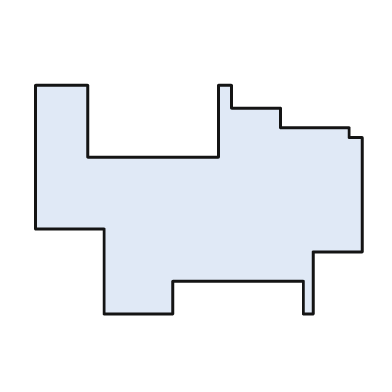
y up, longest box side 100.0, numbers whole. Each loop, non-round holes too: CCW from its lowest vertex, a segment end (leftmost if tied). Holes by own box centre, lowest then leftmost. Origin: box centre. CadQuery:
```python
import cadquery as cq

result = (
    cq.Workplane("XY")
    .moveTo(-29.0, -35.0)
    .lineTo(-8.0, -35.0)
    .lineTo(-8.0, -25.0)
    .lineTo(32.0, -25.0)
    .lineTo(32.0, -35.0)
    .lineTo(35.0, -35.0)
    .lineTo(35.0, -16.0)
    .lineTo(50.0, -16.0)
    .lineTo(50.0, 19.0)
    .lineTo(46.0, 19.0)
    .lineTo(46.0, 22.0)
    .lineTo(25.0, 22.0)
    .lineTo(25.0, 28.0)
    .lineTo(10.0, 28.0)
    .lineTo(10.0, 35.0)
    .lineTo(6.0, 35.0)
    .lineTo(6.0, 13.0)
    .lineTo(-34.0, 13.0)
    .lineTo(-34.0, 35.0)
    .lineTo(-50.0, 35.0)
    .lineTo(-50.0, -9.0)
    .lineTo(-29.0, -9.0)
    .close()
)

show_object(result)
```